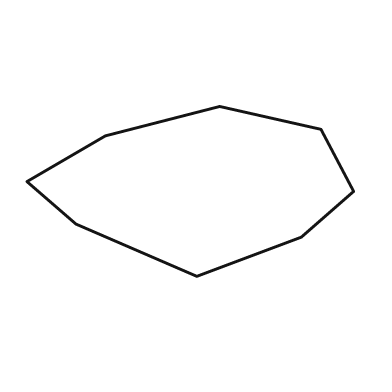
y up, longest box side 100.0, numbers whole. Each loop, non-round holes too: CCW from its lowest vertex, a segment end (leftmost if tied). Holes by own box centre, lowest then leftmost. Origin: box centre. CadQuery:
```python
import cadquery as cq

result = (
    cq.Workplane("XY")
    .moveTo(2.0, -26.0)
    .lineTo(34.0, -14.0)
    .lineTo(50.0, 0.0)
    .lineTo(40.0, 19.0)
    .lineTo(9.0, 26.0)
    .lineTo(-26.0, 17.0)
    .lineTo(-50.0, 3.0)
    .lineTo(-35.0, -10.0)
    .close()
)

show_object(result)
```